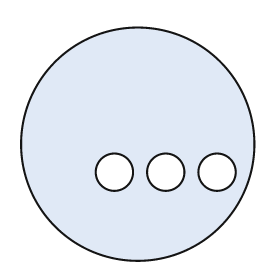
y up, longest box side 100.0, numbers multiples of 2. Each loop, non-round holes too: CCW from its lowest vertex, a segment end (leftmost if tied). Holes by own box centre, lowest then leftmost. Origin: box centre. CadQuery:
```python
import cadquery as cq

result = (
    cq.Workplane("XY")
    .moveTo(0.0, 0.0)
    .circle(50.0)
    .moveTo(-10.0, -12.0)
    .circle(8.0)
    .moveTo(12.0, -12.0)
    .circle(8.0)
    .moveTo(34.0, -12.0)
    .circle(8.0)
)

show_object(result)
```